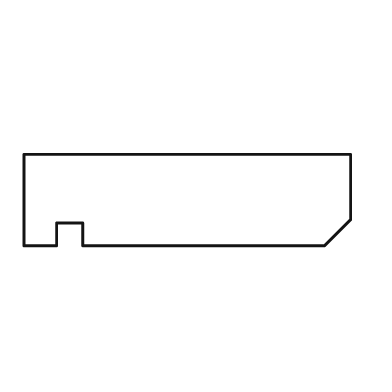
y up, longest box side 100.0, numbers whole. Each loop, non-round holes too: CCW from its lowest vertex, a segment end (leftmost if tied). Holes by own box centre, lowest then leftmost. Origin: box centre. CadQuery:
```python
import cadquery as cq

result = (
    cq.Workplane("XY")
    .moveTo(-50.0, -14.0)
    .lineTo(-40.0, -14.0)
    .lineTo(-40.0, -7.0)
    .lineTo(-32.0, -7.0)
    .lineTo(-32.0, -14.0)
    .lineTo(42.0, -14.0)
    .lineTo(50.0, -6.0)
    .lineTo(50.0, 14.0)
    .lineTo(-50.0, 14.0)
    .close()
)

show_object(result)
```